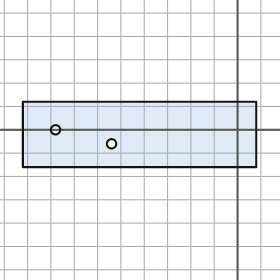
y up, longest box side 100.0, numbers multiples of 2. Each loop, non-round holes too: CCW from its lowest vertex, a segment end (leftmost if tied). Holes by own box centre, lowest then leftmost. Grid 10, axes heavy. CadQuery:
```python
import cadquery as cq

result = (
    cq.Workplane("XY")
    .moveTo(-92.0, -16.0)
    .lineTo(8.0, -16.0)
    .lineTo(8.0, 12.0)
    .lineTo(-92.0, 12.0)
    .close()
    .moveTo(-54.0, -6.0)
    .circle(2.0)
    .moveTo(-78.0, 0.0)
    .circle(2.0)
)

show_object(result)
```